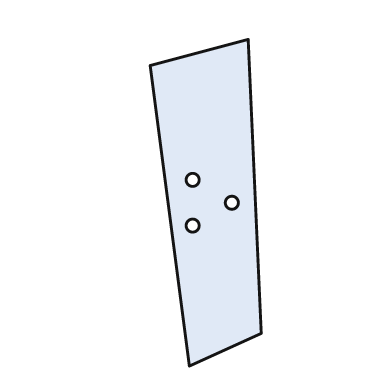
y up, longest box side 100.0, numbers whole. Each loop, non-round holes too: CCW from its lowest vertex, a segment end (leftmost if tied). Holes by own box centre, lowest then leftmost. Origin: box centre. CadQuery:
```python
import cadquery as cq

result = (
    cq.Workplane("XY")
    .moveTo(-5.0, -50.0)
    .lineTo(17.0, -40.0)
    .lineTo(13.0, 50.0)
    .lineTo(-17.0, 42.0)
    .close()
    .moveTo(-4.0, -7.0)
    .circle(2.0)
    .moveTo(8.0, 0.0)
    .circle(2.0)
    .moveTo(-4.0, 7.0)
    .circle(2.0)
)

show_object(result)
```